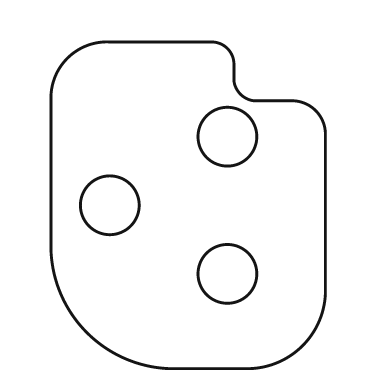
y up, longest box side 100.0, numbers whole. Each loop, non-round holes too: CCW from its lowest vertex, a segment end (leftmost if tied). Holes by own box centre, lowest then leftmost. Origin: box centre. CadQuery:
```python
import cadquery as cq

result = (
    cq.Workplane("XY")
    .moveTo(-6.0, -50.0)
    .lineTo(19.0, -50.0)
    .threePointArc((35.0, -43.0), (42.0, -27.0))
    .lineTo(42.0, 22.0)
    .threePointArc((39.0, 29.0), (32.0, 32.0))
    .lineTo(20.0, 32.0)
    .threePointArc((16.0, 34.0), (14.0, 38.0))
    .lineTo(14.0, 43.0)
    .threePointArc((12.0, 48.0), (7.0, 50.0))
    .lineTo(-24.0, 50.0)
    .threePointArc((-37.0, 45.0), (-42.0, 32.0))
    .lineTo(-42.0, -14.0)
    .threePointArc((-31.0, -39.0), (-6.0, -50.0))
    .close()
    .moveTo(12.0, -21.0)
    .circle(9.0)
    .moveTo(-24.0, 0.0)
    .circle(9.0)
    .moveTo(12.0, 21.0)
    .circle(9.0)
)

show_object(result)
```